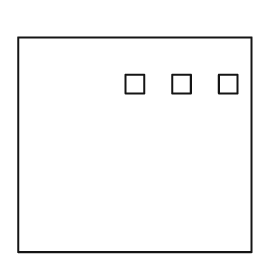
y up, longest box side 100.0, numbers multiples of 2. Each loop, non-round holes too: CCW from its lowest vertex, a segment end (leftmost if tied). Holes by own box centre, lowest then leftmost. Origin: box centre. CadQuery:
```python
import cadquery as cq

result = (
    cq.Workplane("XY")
    .moveTo(-50.0, -46.0)
    .lineTo(50.0, -46.0)
    .lineTo(50.0, 46.0)
    .lineTo(-50.0, 46.0)
    .close()
    .moveTo(-4.0, 22.0)
    .lineTo(4.0, 22.0)
    .lineTo(4.0, 30.0)
    .lineTo(-4.0, 30.0)
    .close()
    .moveTo(16.0, 22.0)
    .lineTo(24.0, 22.0)
    .lineTo(24.0, 30.0)
    .lineTo(16.0, 30.0)
    .close()
    .moveTo(36.0, 22.0)
    .lineTo(44.0, 22.0)
    .lineTo(44.0, 30.0)
    .lineTo(36.0, 30.0)
    .close()
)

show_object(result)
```